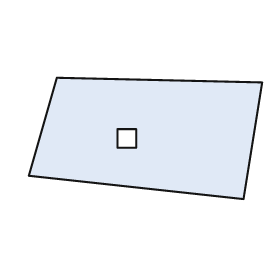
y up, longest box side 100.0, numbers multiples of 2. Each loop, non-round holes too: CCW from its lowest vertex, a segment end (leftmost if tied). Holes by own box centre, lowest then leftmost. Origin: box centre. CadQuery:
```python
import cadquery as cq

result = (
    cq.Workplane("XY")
    .moveTo(42.0, -26.0)
    .lineTo(50.0, 24.0)
    .lineTo(-38.0, 26.0)
    .lineTo(-50.0, -16.0)
    .close()
    .moveTo(-12.0, -4.0)
    .lineTo(-4.0, -4.0)
    .lineTo(-4.0, 4.0)
    .lineTo(-12.0, 4.0)
    .close()
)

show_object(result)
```